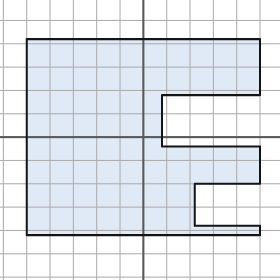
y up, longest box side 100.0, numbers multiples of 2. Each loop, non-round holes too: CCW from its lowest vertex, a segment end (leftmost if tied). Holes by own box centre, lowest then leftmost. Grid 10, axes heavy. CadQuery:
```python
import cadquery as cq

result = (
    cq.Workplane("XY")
    .moveTo(-50.0, -42.0)
    .lineTo(50.0, -42.0)
    .lineTo(50.0, -38.0)
    .lineTo(22.0, -38.0)
    .lineTo(22.0, -20.0)
    .lineTo(50.0, -20.0)
    .lineTo(50.0, -4.0)
    .lineTo(8.0, -4.0)
    .lineTo(8.0, 18.0)
    .lineTo(50.0, 18.0)
    .lineTo(50.0, 42.0)
    .lineTo(-50.0, 42.0)
    .close()
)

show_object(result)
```